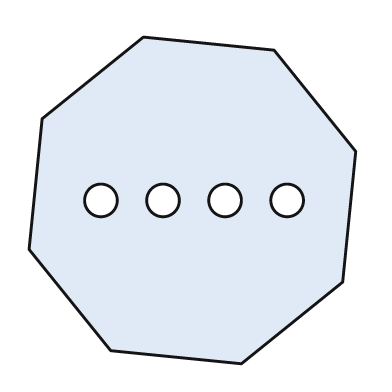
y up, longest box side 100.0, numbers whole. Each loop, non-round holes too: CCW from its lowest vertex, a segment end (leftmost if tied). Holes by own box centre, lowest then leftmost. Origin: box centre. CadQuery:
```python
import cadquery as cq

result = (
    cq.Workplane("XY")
    .moveTo(15.0, -50.0)
    .lineTo(46.0, -25.0)
    .lineTo(50.0, 15.0)
    .lineTo(25.0, 46.0)
    .lineTo(-15.0, 50.0)
    .lineTo(-46.0, 25.0)
    .lineTo(-50.0, -15.0)
    .lineTo(-25.0, -46.0)
    .close()
    .moveTo(-28.0, 0.0)
    .circle(5.0)
    .moveTo(-9.0, 0.0)
    .circle(5.0)
    .moveTo(10.0, 0.0)
    .circle(5.0)
    .moveTo(29.0, 0.0)
    .circle(5.0)
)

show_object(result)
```